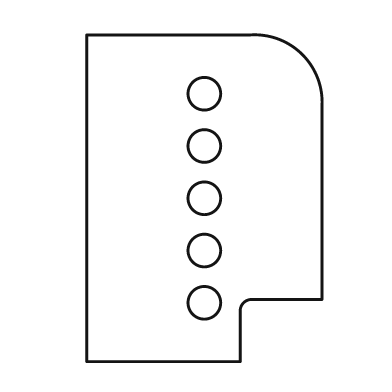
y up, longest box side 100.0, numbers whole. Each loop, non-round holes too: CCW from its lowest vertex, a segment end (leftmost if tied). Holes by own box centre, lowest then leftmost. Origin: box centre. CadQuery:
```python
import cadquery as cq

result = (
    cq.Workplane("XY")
    .moveTo(-36.0, -50.0)
    .lineTo(11.0, -50.0)
    .lineTo(11.0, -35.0)
    .threePointArc((12.0, -32.0), (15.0, -31.0))
    .lineTo(36.0, -31.0)
    .lineTo(36.0, 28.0)
    .threePointArc((30.0, 44.0), (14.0, 50.0))
    .lineTo(-36.0, 50.0)
    .close()
    .moveTo(0.0, -32.0)
    .circle(5.0)
    .moveTo(0.0, -16.0)
    .circle(5.0)
    .moveTo(0.0, 0.0)
    .circle(5.0)
    .moveTo(0.0, 16.0)
    .circle(5.0)
    .moveTo(0.0, 32.0)
    .circle(5.0)
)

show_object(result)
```